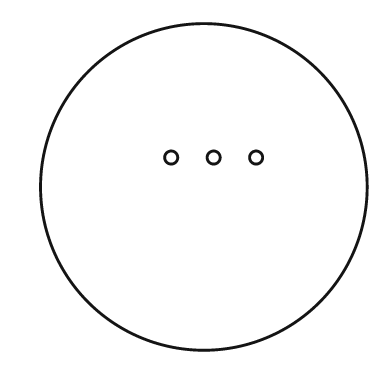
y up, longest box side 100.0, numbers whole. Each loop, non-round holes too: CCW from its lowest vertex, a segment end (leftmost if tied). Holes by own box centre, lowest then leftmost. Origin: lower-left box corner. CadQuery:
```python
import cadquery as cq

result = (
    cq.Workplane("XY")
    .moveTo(50.0, 50.0)
    .circle(50.0)
    .moveTo(40.0, 59.0)
    .circle(2.0)
    .moveTo(53.0, 59.0)
    .circle(2.0)
    .moveTo(66.0, 59.0)
    .circle(2.0)
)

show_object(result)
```